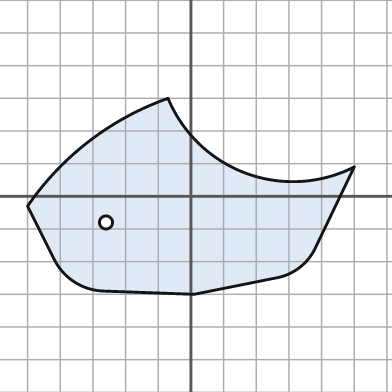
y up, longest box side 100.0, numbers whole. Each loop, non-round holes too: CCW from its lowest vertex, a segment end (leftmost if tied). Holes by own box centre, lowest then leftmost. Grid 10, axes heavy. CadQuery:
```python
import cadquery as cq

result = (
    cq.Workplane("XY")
    .moveTo(1.0, -30.0)
    .lineTo(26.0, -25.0)
    .threePointArc((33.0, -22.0), (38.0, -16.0))
    .lineTo(50.0, 9.0)
    .threePointArc((17.0, 7.0), (-7.0, 30.0))
    .threePointArc((-31.0, 17.0), (-50.0, -3.0))
    .lineTo(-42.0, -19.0)
    .threePointArc((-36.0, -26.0), (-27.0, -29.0))
    .close()
    .moveTo(-26.0, -8.0)
    .circle(2.0)
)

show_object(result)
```